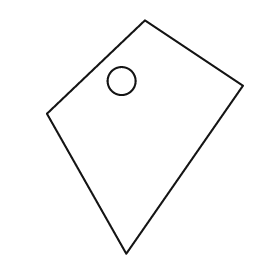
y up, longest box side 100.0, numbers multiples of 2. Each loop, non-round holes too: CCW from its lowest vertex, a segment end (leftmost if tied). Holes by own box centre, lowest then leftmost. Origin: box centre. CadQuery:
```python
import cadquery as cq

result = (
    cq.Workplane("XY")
    .moveTo(-8.0, -50.0)
    .lineTo(42.0, 22.0)
    .lineTo(0.0, 50.0)
    .lineTo(-42.0, 10.0)
    .close()
    .moveTo(-10.0, 24.0)
    .circle(6.0)
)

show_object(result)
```